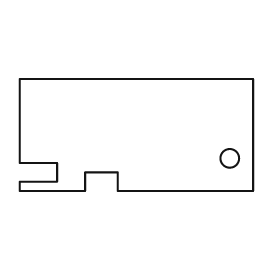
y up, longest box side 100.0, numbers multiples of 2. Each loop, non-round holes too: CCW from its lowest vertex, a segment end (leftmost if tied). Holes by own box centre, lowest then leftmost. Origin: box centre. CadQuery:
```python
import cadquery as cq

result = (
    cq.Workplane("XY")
    .moveTo(-50.0, -24.0)
    .lineTo(-22.0, -24.0)
    .lineTo(-22.0, -16.0)
    .lineTo(-8.0, -16.0)
    .lineTo(-8.0, -24.0)
    .lineTo(50.0, -24.0)
    .lineTo(50.0, 24.0)
    .lineTo(-50.0, 24.0)
    .lineTo(-50.0, -12.0)
    .lineTo(-34.0, -12.0)
    .lineTo(-34.0, -20.0)
    .lineTo(-50.0, -20.0)
    .close()
    .moveTo(40.0, -10.0)
    .circle(4.0)
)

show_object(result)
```